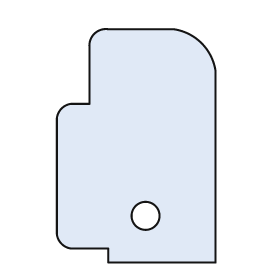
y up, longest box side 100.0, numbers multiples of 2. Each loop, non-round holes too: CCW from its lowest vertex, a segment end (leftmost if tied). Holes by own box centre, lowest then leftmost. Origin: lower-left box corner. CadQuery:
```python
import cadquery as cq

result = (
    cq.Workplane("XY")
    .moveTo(22.0, 0.0)
    .lineTo(68.0, 0.0)
    .lineTo(68.0, 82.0)
    .threePointArc((62.0, 94.0), (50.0, 100.0))
    .lineTo(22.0, 100.0)
    .threePointArc((16.0, 98.0), (14.0, 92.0))
    .lineTo(14.0, 68.0)
    .lineTo(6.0, 68.0)
    .threePointArc((2.0, 66.0), (0.0, 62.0))
    .lineTo(0.0, 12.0)
    .threePointArc((2.0, 8.0), (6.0, 6.0))
    .lineTo(22.0, 6.0)
    .close()
    .moveTo(38.0, 20.0)
    .circle(6.0)
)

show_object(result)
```